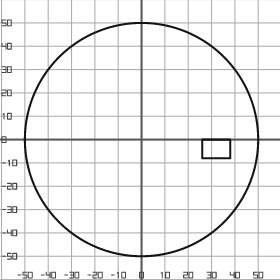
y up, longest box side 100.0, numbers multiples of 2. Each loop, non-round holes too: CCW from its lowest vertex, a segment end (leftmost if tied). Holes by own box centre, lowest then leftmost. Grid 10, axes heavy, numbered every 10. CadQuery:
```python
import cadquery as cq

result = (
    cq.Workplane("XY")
    .moveTo(0.0, 0.0)
    .circle(50.0)
    .moveTo(26.0, -8.0)
    .lineTo(38.0, -8.0)
    .lineTo(38.0, 0.0)
    .lineTo(26.0, 0.0)
    .close()
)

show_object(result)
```